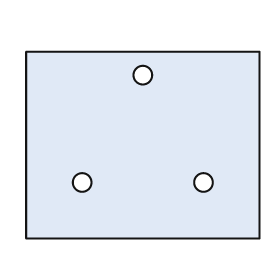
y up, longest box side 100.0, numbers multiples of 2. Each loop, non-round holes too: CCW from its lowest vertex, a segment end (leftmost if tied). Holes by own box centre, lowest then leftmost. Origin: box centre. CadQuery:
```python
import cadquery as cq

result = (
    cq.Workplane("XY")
    .moveTo(-50.0, -40.0)
    .lineTo(50.0, -40.0)
    .lineTo(50.0, 40.0)
    .lineTo(-50.0, 40.0)
    .close()
    .moveTo(-26.0, -16.0)
    .circle(4.0)
    .moveTo(26.0, -16.0)
    .circle(4.0)
    .moveTo(0.0, 30.0)
    .circle(4.0)
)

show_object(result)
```